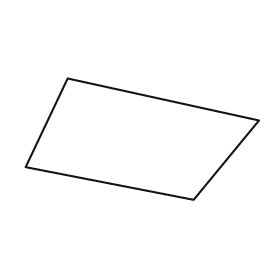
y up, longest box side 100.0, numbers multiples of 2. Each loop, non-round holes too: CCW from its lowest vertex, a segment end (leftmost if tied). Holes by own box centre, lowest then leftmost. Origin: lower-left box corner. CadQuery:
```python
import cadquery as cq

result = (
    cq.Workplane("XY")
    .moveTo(72.0, 0.0)
    .lineTo(100.0, 34.0)
    .lineTo(18.0, 52.0)
    .lineTo(0.0, 14.0)
    .close()
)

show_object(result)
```